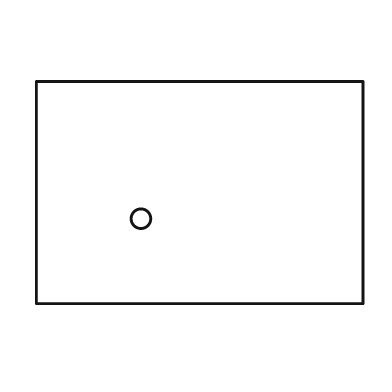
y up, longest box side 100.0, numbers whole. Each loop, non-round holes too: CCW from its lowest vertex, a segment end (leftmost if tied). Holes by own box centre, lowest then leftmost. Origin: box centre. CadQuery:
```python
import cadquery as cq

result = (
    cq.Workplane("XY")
    .moveTo(-50.0, -34.0)
    .lineTo(50.0, -34.0)
    .lineTo(50.0, 34.0)
    .lineTo(-50.0, 34.0)
    .close()
    .moveTo(-18.0, -8.0)
    .circle(3.0)
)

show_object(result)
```